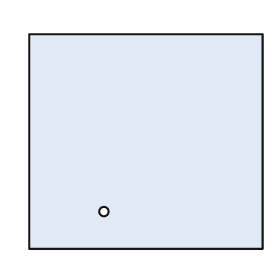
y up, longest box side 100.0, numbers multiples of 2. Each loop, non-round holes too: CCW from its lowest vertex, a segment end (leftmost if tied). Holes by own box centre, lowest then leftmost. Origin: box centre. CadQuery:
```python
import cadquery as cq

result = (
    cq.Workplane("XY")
    .moveTo(-50.0, -46.0)
    .lineTo(50.0, -46.0)
    .lineTo(50.0, 46.0)
    .lineTo(-50.0, 46.0)
    .close()
    .moveTo(-18.0, -30.0)
    .circle(2.0)
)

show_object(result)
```